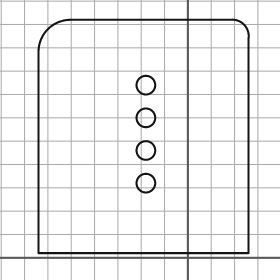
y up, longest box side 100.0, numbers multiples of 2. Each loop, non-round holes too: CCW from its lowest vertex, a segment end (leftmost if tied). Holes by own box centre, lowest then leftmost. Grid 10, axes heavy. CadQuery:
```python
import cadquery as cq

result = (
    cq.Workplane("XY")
    .moveTo(-64.0, 2.0)
    .lineTo(26.0, 2.0)
    .lineTo(26.0, 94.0)
    .threePointArc((24.0, 100.0), (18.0, 102.0))
    .lineTo(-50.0, 102.0)
    .threePointArc((-60.0, 98.0), (-64.0, 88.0))
    .close()
    .moveTo(-18.0, 32.0)
    .circle(4.0)
    .moveTo(-18.0, 46.0)
    .circle(4.0)
    .moveTo(-18.0, 60.0)
    .circle(4.0)
    .moveTo(-18.0, 74.0)
    .circle(4.0)
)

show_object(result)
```